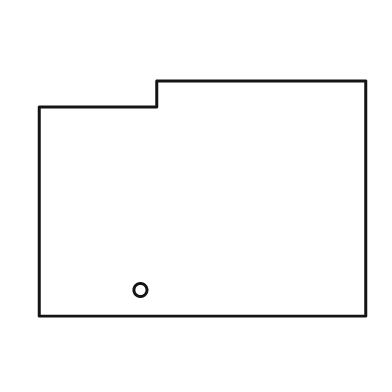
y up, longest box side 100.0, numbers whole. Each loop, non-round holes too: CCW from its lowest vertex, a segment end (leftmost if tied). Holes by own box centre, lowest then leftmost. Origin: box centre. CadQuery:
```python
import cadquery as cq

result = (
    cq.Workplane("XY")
    .moveTo(-50.0, -36.0)
    .lineTo(50.0, -36.0)
    .lineTo(50.0, 36.0)
    .lineTo(-14.0, 36.0)
    .lineTo(-14.0, 28.0)
    .lineTo(-50.0, 28.0)
    .close()
    .moveTo(-19.0, -28.0)
    .circle(2.0)
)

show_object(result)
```